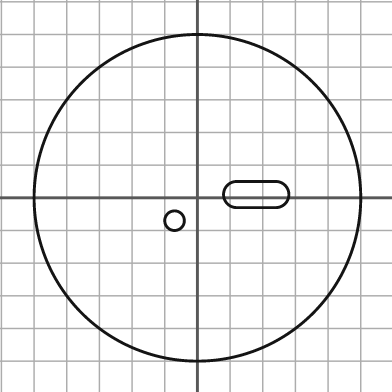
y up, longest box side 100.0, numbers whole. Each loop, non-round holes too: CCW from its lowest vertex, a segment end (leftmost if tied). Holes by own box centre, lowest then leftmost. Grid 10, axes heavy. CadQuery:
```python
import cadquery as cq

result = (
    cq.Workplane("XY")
    .moveTo(0.0, 0.0)
    .circle(50.0)
    .moveTo(-7.0, -7.0)
    .circle(3.0)
    .moveTo(12.0, -3.0)
    .lineTo(24.0, -3.0)
    .threePointArc((28.0, 1.0), (24.0, 5.0))
    .lineTo(12.0, 5.0)
    .threePointArc((8.0, 1.0), (12.0, -3.0))
    .close()
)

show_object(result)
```